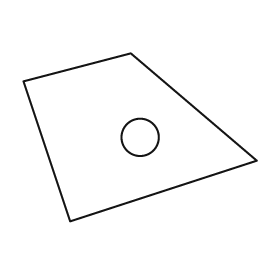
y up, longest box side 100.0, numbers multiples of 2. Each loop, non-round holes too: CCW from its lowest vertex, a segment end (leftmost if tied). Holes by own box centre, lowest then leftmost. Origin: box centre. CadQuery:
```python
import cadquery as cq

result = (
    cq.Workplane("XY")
    .moveTo(-30.0, -36.0)
    .lineTo(50.0, -10.0)
    .lineTo(-4.0, 36.0)
    .lineTo(-50.0, 24.0)
    .close()
    .moveTo(0.0, 0.0)
    .circle(8.0)
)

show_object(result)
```